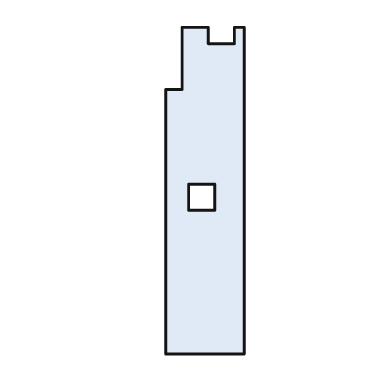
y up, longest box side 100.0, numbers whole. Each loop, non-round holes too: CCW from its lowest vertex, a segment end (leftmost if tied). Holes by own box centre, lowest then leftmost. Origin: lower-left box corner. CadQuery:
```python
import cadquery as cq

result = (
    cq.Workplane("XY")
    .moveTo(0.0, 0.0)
    .lineTo(24.0, 0.0)
    .lineTo(24.0, 100.0)
    .lineTo(21.0, 100.0)
    .lineTo(21.0, 95.0)
    .lineTo(13.0, 95.0)
    .lineTo(13.0, 100.0)
    .lineTo(5.0, 100.0)
    .lineTo(5.0, 81.0)
    .lineTo(0.0, 81.0)
    .close()
    .moveTo(7.0, 44.0)
    .lineTo(15.0, 44.0)
    .lineTo(15.0, 52.0)
    .lineTo(7.0, 52.0)
    .close()
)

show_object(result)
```